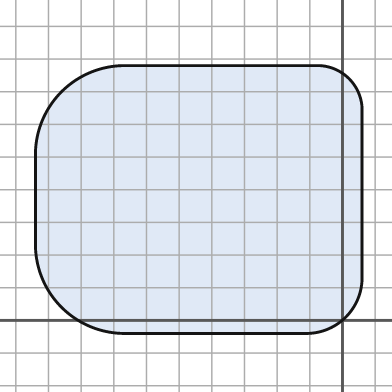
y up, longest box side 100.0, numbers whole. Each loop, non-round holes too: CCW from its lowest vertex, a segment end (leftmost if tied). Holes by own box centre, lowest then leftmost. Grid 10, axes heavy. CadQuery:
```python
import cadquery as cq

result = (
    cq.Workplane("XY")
    .moveTo(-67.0, -4.0)
    .lineTo(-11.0, -4.0)
    .threePointArc((1.0, 1.0), (6.0, 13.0))
    .lineTo(6.0, 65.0)
    .threePointArc((2.0, 74.0), (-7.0, 78.0))
    .lineTo(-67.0, 78.0)
    .threePointArc((-86.0, 70.0), (-94.0, 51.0))
    .lineTo(-94.0, 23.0)
    .threePointArc((-86.0, 4.0), (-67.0, -4.0))
    .close()
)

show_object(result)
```